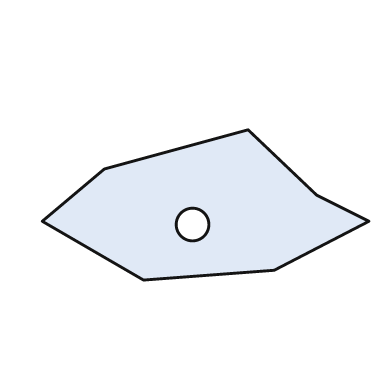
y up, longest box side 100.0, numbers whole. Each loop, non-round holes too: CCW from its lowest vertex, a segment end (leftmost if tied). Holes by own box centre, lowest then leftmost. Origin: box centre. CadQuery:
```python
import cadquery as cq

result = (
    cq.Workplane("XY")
    .moveTo(-19.0, -23.0)
    .lineTo(21.0, -20.0)
    .lineTo(50.0, -5.0)
    .lineTo(34.0, 3.0)
    .lineTo(13.0, 23.0)
    .lineTo(-31.0, 11.0)
    .lineTo(-50.0, -5.0)
    .close()
    .moveTo(-4.0, -6.0)
    .circle(5.0)
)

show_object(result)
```